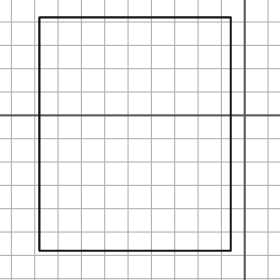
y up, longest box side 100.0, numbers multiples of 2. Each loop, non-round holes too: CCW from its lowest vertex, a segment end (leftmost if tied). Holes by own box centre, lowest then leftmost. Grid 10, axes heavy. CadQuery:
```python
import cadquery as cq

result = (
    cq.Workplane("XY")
    .moveTo(-88.0, -58.0)
    .lineTo(-6.0, -58.0)
    .lineTo(-6.0, 42.0)
    .lineTo(-88.0, 42.0)
    .close()
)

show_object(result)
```